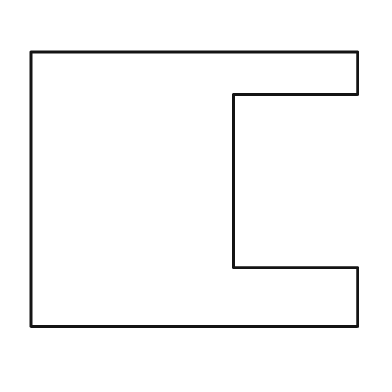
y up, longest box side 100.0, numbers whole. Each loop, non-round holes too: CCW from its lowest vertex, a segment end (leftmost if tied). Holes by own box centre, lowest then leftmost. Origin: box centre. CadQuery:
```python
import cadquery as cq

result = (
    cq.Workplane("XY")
    .moveTo(-50.0, -42.0)
    .lineTo(50.0, -42.0)
    .lineTo(50.0, -24.0)
    .lineTo(12.0, -24.0)
    .lineTo(12.0, 29.0)
    .lineTo(50.0, 29.0)
    .lineTo(50.0, 42.0)
    .lineTo(-50.0, 42.0)
    .close()
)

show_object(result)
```